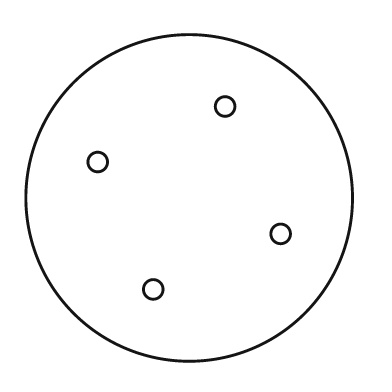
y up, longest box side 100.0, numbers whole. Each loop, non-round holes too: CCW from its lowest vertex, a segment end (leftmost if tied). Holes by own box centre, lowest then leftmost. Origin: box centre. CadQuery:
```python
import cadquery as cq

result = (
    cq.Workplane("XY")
    .moveTo(0.0, 0.0)
    .circle(50.0)
    .moveTo(-11.0, -28.0)
    .circle(3.0)
    .moveTo(28.0, -11.0)
    .circle(3.0)
    .moveTo(-28.0, 11.0)
    .circle(3.0)
    .moveTo(11.0, 28.0)
    .circle(3.0)
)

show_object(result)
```